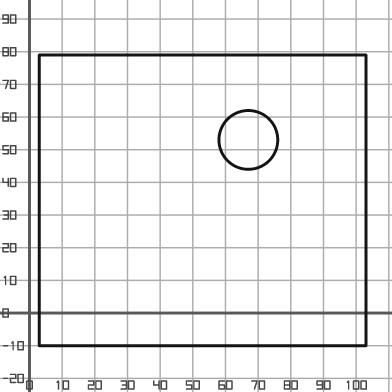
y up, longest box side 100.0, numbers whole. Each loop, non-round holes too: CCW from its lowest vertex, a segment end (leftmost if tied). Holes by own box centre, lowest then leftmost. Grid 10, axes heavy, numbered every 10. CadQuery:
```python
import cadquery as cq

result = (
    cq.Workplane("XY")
    .moveTo(3.0, -10.0)
    .lineTo(103.0, -10.0)
    .lineTo(103.0, 79.0)
    .lineTo(3.0, 79.0)
    .close()
    .moveTo(67.0, 53.0)
    .circle(9.0)
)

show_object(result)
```